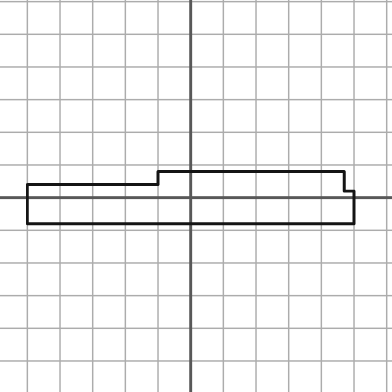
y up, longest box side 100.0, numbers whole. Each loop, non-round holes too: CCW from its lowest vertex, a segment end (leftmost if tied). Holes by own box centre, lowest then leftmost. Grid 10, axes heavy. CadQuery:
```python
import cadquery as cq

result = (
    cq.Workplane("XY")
    .moveTo(-50.0, -8.0)
    .lineTo(50.0, -8.0)
    .lineTo(50.0, 2.0)
    .lineTo(47.0, 2.0)
    .lineTo(47.0, 8.0)
    .lineTo(-10.0, 8.0)
    .lineTo(-10.0, 4.0)
    .lineTo(-50.0, 4.0)
    .close()
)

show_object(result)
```